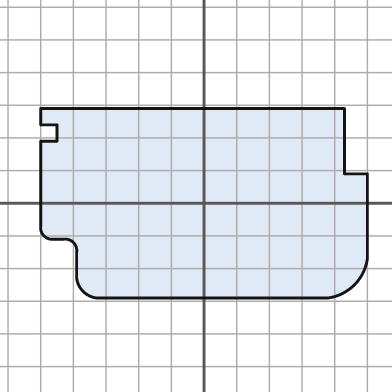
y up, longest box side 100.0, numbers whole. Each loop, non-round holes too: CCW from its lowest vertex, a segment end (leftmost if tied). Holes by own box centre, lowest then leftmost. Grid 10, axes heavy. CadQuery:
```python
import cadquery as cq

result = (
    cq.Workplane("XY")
    .moveTo(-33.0, -29.0)
    .lineTo(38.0, -29.0)
    .threePointArc((46.0, -25.0), (50.0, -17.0))
    .lineTo(50.0, 9.0)
    .lineTo(43.0, 9.0)
    .lineTo(43.0, 29.0)
    .lineTo(-50.0, 29.0)
    .lineTo(-50.0, 24.0)
    .lineTo(-45.0, 24.0)
    .lineTo(-45.0, 19.0)
    .lineTo(-50.0, 19.0)
    .lineTo(-50.0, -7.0)
    .threePointArc((-49.0, -10.0), (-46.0, -11.0))
    .lineTo(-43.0, -11.0)
    .threePointArc((-40.0, -12.0), (-39.0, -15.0))
    .lineTo(-39.0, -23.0)
    .threePointArc((-37.0, -27.0), (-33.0, -29.0))
    .close()
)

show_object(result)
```